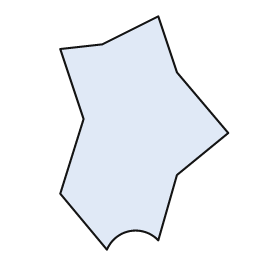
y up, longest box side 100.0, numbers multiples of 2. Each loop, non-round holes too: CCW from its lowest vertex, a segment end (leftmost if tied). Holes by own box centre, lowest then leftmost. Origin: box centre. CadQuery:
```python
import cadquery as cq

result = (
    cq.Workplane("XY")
    .moveTo(-16.0, -50.0)
    .threePointArc((-6.0, -42.0), (6.0, -46.0))
    .lineTo(14.0, -18.0)
    .lineTo(36.0, 0.0)
    .lineTo(14.0, 26.0)
    .lineTo(6.0, 50.0)
    .lineTo(-18.0, 38.0)
    .lineTo(-36.0, 36.0)
    .lineTo(-26.0, 6.0)
    .lineTo(-36.0, -26.0)
    .close()
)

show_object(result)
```